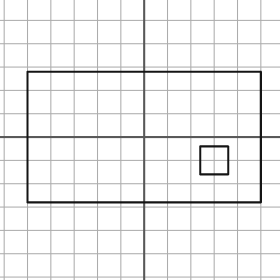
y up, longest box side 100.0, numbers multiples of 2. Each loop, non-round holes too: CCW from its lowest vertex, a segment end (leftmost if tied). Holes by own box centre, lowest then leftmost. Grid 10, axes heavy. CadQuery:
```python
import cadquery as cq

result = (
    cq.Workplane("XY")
    .moveTo(-50.0, -28.0)
    .lineTo(50.0, -28.0)
    .lineTo(50.0, 28.0)
    .lineTo(-50.0, 28.0)
    .close()
    .moveTo(24.0, -16.0)
    .lineTo(36.0, -16.0)
    .lineTo(36.0, -4.0)
    .lineTo(24.0, -4.0)
    .close()
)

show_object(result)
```